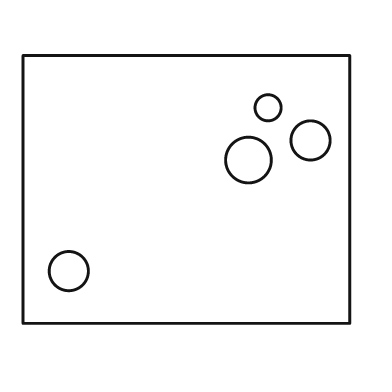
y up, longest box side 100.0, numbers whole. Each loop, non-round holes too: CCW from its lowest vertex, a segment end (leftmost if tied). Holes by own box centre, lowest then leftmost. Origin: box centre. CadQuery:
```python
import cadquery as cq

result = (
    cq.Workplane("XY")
    .moveTo(-50.0, -41.0)
    .lineTo(50.0, -41.0)
    .lineTo(50.0, 41.0)
    .lineTo(-50.0, 41.0)
    .close()
    .moveTo(-36.0, -25.0)
    .circle(6.0)
    .moveTo(19.0, 9.0)
    .circle(7.0)
    .moveTo(38.0, 15.0)
    .circle(6.0)
    .moveTo(25.0, 25.0)
    .circle(4.0)
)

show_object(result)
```